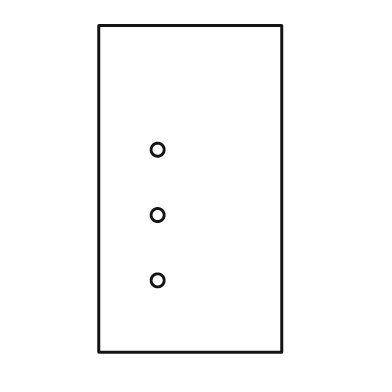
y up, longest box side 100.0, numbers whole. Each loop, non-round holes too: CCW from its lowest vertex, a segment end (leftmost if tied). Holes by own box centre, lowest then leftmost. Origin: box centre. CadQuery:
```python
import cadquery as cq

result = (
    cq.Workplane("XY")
    .moveTo(-28.0, -50.0)
    .lineTo(28.0, -50.0)
    .lineTo(28.0, 50.0)
    .lineTo(-28.0, 50.0)
    .close()
    .moveTo(-10.0, -28.0)
    .circle(2.0)
    .moveTo(-10.0, -8.0)
    .circle(2.0)
    .moveTo(-10.0, 12.0)
    .circle(2.0)
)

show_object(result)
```